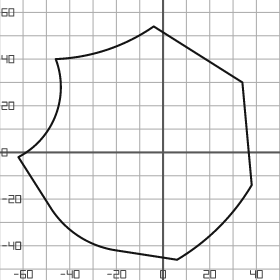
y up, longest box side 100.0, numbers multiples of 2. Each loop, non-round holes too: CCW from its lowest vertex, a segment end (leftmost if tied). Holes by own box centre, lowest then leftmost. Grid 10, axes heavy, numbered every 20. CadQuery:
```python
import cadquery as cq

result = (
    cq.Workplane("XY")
    .moveTo(6.0, -46.0)
    .threePointArc((24.0, -32.0), (38.0, -14.0))
    .lineTo(34.0, 30.0)
    .lineTo(-4.0, 54.0)
    .threePointArc((-24.0, 44.0), (-46.0, 40.0))
    .threePointArc((-46.0, 16.0), (-62.0, -2.0))
    .lineTo(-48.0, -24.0)
    .threePointArc((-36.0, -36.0), (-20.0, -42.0))
    .close()
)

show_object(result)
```